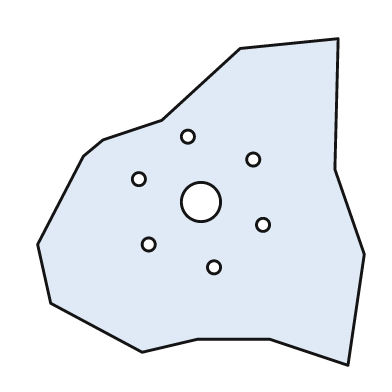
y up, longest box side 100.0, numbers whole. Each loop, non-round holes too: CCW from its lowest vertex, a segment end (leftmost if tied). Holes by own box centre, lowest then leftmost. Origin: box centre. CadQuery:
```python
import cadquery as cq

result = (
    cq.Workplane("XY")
    .moveTo(45.0, -50.0)
    .lineTo(50.0, -16.0)
    .lineTo(41.0, 10.0)
    .lineTo(42.0, 50.0)
    .lineTo(12.0, 47.0)
    .lineTo(-12.0, 25.0)
    .lineTo(-30.0, 19.0)
    .lineTo(-36.0, 14.0)
    .lineTo(-50.0, -13.0)
    .lineTo(-46.0, -31.0)
    .lineTo(-18.0, -46.0)
    .lineTo(-1.0, -42.0)
    .lineTo(21.0, -42.0)
    .close()
    .moveTo(4.0, -20.0)
    .circle(2.0)
    .moveTo(-16.0, -13.0)
    .circle(2.0)
    .moveTo(19.0, -7.0)
    .circle(2.0)
    .moveTo(0.0, 0.0)
    .circle(6.0)
    .moveTo(-19.0, 7.0)
    .circle(2.0)
    .moveTo(16.0, 13.0)
    .circle(2.0)
    .moveTo(-4.0, 20.0)
    .circle(2.0)
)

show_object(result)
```